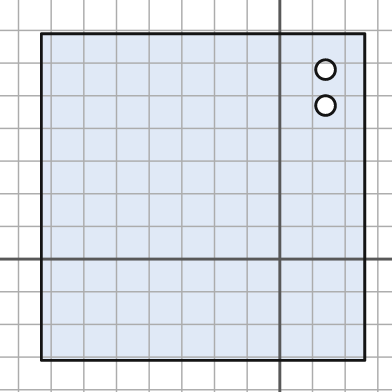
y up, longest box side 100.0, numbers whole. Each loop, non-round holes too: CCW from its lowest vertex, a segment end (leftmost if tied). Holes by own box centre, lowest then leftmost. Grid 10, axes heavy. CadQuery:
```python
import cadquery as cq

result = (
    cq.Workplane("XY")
    .moveTo(-73.0, -31.0)
    .lineTo(26.0, -31.0)
    .lineTo(26.0, 69.0)
    .lineTo(-73.0, 69.0)
    .close()
    .moveTo(14.0, 47.0)
    .circle(3.0)
    .moveTo(14.0, 58.0)
    .circle(3.0)
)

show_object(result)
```